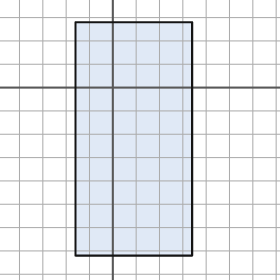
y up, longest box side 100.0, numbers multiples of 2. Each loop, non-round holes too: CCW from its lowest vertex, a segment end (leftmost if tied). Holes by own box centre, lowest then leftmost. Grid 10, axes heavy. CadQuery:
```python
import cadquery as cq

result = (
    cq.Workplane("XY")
    .moveTo(-16.0, -72.0)
    .lineTo(34.0, -72.0)
    .lineTo(34.0, 28.0)
    .lineTo(-16.0, 28.0)
    .close()
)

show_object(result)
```